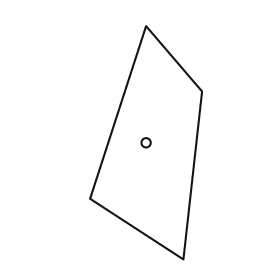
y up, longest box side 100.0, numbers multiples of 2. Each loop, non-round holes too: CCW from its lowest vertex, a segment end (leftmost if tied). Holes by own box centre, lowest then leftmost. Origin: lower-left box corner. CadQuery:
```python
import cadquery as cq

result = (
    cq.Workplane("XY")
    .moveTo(40.0, 0.0)
    .lineTo(48.0, 72.0)
    .lineTo(24.0, 100.0)
    .lineTo(0.0, 26.0)
    .close()
    .moveTo(24.0, 50.0)
    .circle(2.0)
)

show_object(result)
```